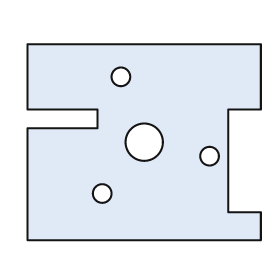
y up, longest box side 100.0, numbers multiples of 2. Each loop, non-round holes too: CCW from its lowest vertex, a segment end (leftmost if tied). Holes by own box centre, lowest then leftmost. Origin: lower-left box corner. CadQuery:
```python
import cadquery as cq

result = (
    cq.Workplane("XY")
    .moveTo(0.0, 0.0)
    .lineTo(100.0, 0.0)
    .lineTo(100.0, 12.0)
    .lineTo(86.0, 12.0)
    .lineTo(86.0, 56.0)
    .lineTo(100.0, 56.0)
    .lineTo(100.0, 84.0)
    .lineTo(0.0, 84.0)
    .lineTo(0.0, 56.0)
    .lineTo(30.0, 56.0)
    .lineTo(30.0, 48.0)
    .lineTo(0.0, 48.0)
    .close()
    .moveTo(32.0, 20.0)
    .circle(4.0)
    .moveTo(78.0, 36.0)
    .circle(4.0)
    .moveTo(50.0, 42.0)
    .circle(8.0)
    .moveTo(40.0, 70.0)
    .circle(4.0)
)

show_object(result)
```